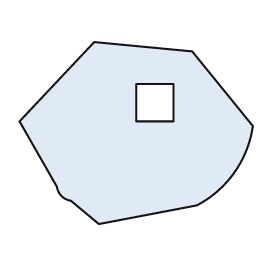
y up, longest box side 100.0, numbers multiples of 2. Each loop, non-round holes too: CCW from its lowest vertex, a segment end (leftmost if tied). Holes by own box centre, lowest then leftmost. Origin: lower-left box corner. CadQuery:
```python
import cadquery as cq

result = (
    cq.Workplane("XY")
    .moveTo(34.0, 0.0)
    .lineTo(76.0, 8.0)
    .threePointArc((92.0, 22.0), (100.0, 42.0))
    .lineTo(74.0, 74.0)
    .lineTo(32.0, 78.0)
    .lineTo(0.0, 44.0)
    .lineTo(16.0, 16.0)
    .threePointArc((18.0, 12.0), (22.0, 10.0))
    .close()
    .moveTo(50.0, 44.0)
    .lineTo(66.0, 44.0)
    .lineTo(66.0, 60.0)
    .lineTo(50.0, 60.0)
    .close()
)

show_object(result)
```